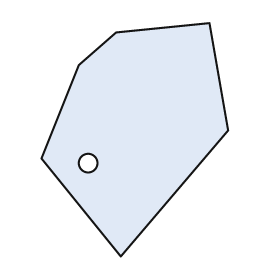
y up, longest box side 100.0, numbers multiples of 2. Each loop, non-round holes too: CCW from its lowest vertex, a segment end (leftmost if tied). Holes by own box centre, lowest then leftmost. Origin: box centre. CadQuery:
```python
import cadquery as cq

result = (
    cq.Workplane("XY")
    .moveTo(-6.0, -50.0)
    .lineTo(40.0, 4.0)
    .lineTo(32.0, 50.0)
    .lineTo(-8.0, 46.0)
    .lineTo(-24.0, 32.0)
    .lineTo(-40.0, -8.0)
    .close()
    .moveTo(-20.0, -10.0)
    .circle(4.0)
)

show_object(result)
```